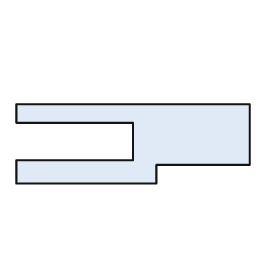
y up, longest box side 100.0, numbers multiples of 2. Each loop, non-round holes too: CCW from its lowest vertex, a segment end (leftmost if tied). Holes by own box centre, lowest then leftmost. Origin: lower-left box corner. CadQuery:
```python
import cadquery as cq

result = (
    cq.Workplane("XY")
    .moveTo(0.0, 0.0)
    .lineTo(60.0, 0.0)
    .lineTo(60.0, 8.0)
    .lineTo(100.0, 8.0)
    .lineTo(100.0, 34.0)
    .lineTo(0.0, 34.0)
    .lineTo(0.0, 26.0)
    .lineTo(50.0, 26.0)
    .lineTo(50.0, 10.0)
    .lineTo(0.0, 10.0)
    .close()
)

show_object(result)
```